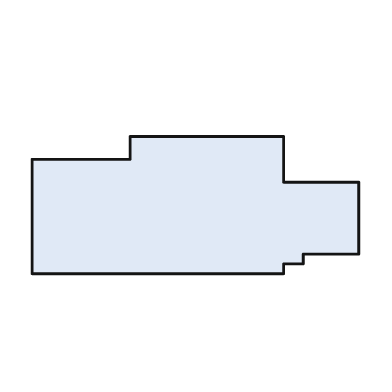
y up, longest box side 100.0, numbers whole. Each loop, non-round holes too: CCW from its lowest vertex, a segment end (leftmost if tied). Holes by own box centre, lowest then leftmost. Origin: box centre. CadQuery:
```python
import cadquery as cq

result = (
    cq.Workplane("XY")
    .moveTo(-50.0, -21.0)
    .lineTo(27.0, -21.0)
    .lineTo(27.0, -18.0)
    .lineTo(33.0, -18.0)
    .lineTo(33.0, -15.0)
    .lineTo(50.0, -15.0)
    .lineTo(50.0, 7.0)
    .lineTo(27.0, 7.0)
    .lineTo(27.0, 21.0)
    .lineTo(-20.0, 21.0)
    .lineTo(-20.0, 14.0)
    .lineTo(-50.0, 14.0)
    .close()
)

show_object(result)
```